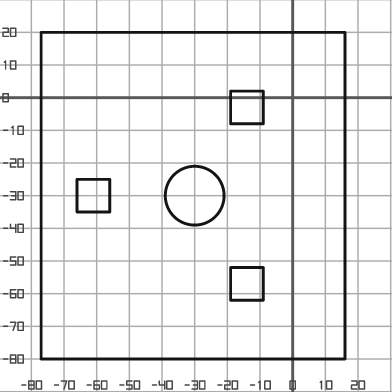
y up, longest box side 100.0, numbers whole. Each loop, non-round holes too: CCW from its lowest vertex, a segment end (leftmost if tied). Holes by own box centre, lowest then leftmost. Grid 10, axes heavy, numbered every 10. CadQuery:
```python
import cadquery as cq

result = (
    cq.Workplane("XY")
    .moveTo(-77.0, -80.0)
    .lineTo(16.0, -80.0)
    .lineTo(16.0, 20.0)
    .lineTo(-77.0, 20.0)
    .close()
    .moveTo(-19.0, -62.0)
    .lineTo(-9.0, -62.0)
    .lineTo(-9.0, -52.0)
    .lineTo(-19.0, -52.0)
    .close()
    .moveTo(-66.0, -35.0)
    .lineTo(-56.0, -35.0)
    .lineTo(-56.0, -25.0)
    .lineTo(-66.0, -25.0)
    .close()
    .moveTo(-30.0, -30.0)
    .circle(9.0)
    .moveTo(-19.0, -8.0)
    .lineTo(-9.0, -8.0)
    .lineTo(-9.0, 2.0)
    .lineTo(-19.0, 2.0)
    .close()
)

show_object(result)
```